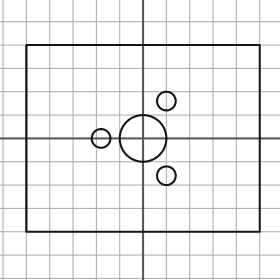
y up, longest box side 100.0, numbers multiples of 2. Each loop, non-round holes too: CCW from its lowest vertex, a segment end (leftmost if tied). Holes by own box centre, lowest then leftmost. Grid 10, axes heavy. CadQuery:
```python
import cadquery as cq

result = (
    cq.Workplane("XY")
    .moveTo(-50.0, -40.0)
    .lineTo(50.0, -40.0)
    .lineTo(50.0, 40.0)
    .lineTo(-50.0, 40.0)
    .close()
    .moveTo(10.0, -16.0)
    .circle(4.0)
    .moveTo(-18.0, 0.0)
    .circle(4.0)
    .moveTo(0.0, 0.0)
    .circle(10.0)
    .moveTo(10.0, 16.0)
    .circle(4.0)
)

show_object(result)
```